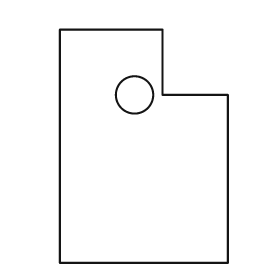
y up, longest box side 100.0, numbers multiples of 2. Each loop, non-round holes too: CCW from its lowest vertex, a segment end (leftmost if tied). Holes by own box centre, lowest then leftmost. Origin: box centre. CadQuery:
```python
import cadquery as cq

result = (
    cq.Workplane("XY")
    .moveTo(-36.0, -50.0)
    .lineTo(36.0, -50.0)
    .lineTo(36.0, 22.0)
    .lineTo(8.0, 22.0)
    .lineTo(8.0, 50.0)
    .lineTo(-36.0, 50.0)
    .close()
    .moveTo(-4.0, 22.0)
    .circle(8.0)
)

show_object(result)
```